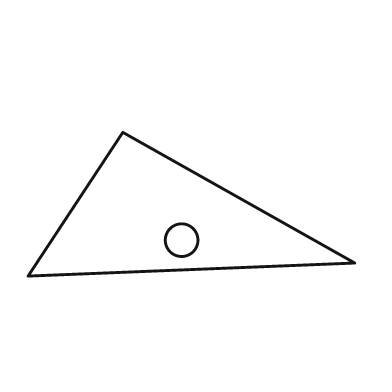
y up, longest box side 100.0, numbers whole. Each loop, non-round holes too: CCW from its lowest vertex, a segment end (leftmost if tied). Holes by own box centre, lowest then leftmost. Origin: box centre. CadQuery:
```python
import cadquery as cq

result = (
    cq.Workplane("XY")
    .moveTo(-50.0, -22.0)
    .lineTo(50.0, -18.0)
    .lineTo(-21.0, 22.0)
    .close()
    .moveTo(-3.0, -11.0)
    .circle(5.0)
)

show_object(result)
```